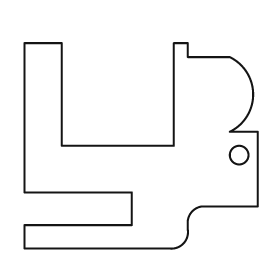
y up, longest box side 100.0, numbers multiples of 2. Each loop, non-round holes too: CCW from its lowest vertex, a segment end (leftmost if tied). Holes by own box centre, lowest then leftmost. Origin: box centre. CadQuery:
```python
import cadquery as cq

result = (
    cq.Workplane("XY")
    .moveTo(-50.0, -44.0)
    .lineTo(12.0, -44.0)
    .threePointArc((18.0, -42.0), (20.0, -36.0))
    .lineTo(20.0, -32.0)
    .threePointArc((22.0, -28.0), (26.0, -26.0))
    .lineTo(50.0, -26.0)
    .lineTo(50.0, 6.0)
    .lineTo(38.0, 6.0)
    .threePointArc((48.0, 22.0), (38.0, 38.0))
    .lineTo(20.0, 38.0)
    .lineTo(20.0, 44.0)
    .lineTo(14.0, 44.0)
    .lineTo(14.0, 0.0)
    .lineTo(-34.0, 0.0)
    .lineTo(-34.0, 44.0)
    .lineTo(-50.0, 44.0)
    .lineTo(-50.0, -20.0)
    .lineTo(-4.0, -20.0)
    .lineTo(-4.0, -34.0)
    .lineTo(-50.0, -34.0)
    .close()
    .moveTo(42.0, -4.0)
    .circle(4.0)
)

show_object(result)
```